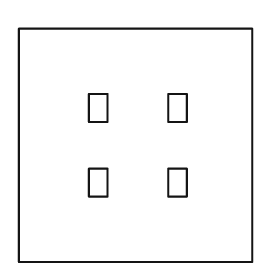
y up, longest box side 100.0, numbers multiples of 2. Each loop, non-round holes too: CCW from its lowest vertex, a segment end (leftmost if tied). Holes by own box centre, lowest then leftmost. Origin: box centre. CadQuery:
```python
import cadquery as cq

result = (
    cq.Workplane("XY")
    .moveTo(-50.0, -50.0)
    .lineTo(50.0, -50.0)
    .lineTo(50.0, 50.0)
    .lineTo(-50.0, 50.0)
    .close()
    .moveTo(-20.0, -22.0)
    .lineTo(-12.0, -22.0)
    .lineTo(-12.0, -10.0)
    .lineTo(-20.0, -10.0)
    .close()
    .moveTo(14.0, -22.0)
    .lineTo(22.0, -22.0)
    .lineTo(22.0, -10.0)
    .lineTo(14.0, -10.0)
    .close()
    .moveTo(-20.0, 10.0)
    .lineTo(-12.0, 10.0)
    .lineTo(-12.0, 22.0)
    .lineTo(-20.0, 22.0)
    .close()
    .moveTo(14.0, 10.0)
    .lineTo(22.0, 10.0)
    .lineTo(22.0, 22.0)
    .lineTo(14.0, 22.0)
    .close()
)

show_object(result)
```